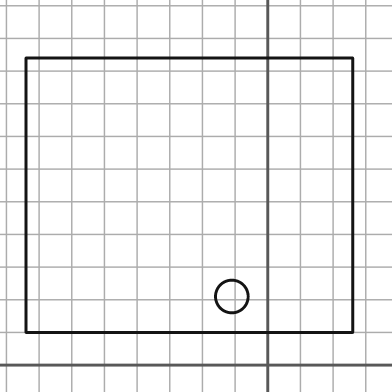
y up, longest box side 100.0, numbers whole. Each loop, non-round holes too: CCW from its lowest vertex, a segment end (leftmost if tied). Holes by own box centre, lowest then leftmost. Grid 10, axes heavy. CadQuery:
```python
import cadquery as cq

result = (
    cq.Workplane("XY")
    .moveTo(-74.0, 10.0)
    .lineTo(26.0, 10.0)
    .lineTo(26.0, 94.0)
    .lineTo(-74.0, 94.0)
    .close()
    .moveTo(-11.0, 21.0)
    .circle(5.0)
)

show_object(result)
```